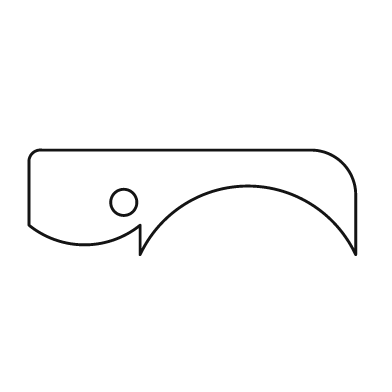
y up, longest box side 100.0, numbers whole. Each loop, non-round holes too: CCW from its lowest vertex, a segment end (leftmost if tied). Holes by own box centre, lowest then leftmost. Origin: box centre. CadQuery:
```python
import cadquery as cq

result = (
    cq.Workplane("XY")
    .moveTo(-16.0, -16.0)
    .threePointArc((17.0, 5.0), (50.0, -16.0))
    .lineTo(50.0, 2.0)
    .threePointArc((46.0, 12.0), (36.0, 16.0))
    .lineTo(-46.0, 16.0)
    .threePointArc((-49.0, 15.0), (-50.0, 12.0))
    .lineTo(-50.0, -7.0)
    .threePointArc((-33.0, -13.0), (-16.0, -7.0))
    .close()
    .moveTo(-21.0, 0.0)
    .circle(4.0)
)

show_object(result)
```